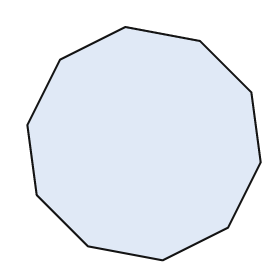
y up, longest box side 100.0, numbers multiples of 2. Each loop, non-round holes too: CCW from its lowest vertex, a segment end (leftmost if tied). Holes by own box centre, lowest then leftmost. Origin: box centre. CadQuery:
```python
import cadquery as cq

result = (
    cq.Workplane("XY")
    .moveTo(8.0, -50.0)
    .lineTo(36.0, -36.0)
    .lineTo(50.0, -8.0)
    .lineTo(46.0, 22.0)
    .lineTo(24.0, 44.0)
    .lineTo(-8.0, 50.0)
    .lineTo(-36.0, 36.0)
    .lineTo(-50.0, 8.0)
    .lineTo(-46.0, -22.0)
    .lineTo(-24.0, -44.0)
    .close()
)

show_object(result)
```